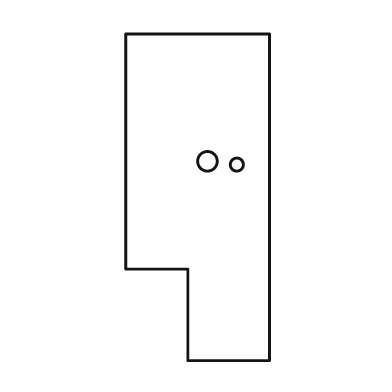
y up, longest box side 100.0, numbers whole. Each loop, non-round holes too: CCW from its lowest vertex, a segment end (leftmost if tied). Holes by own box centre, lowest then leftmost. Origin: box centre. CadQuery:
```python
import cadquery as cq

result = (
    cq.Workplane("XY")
    .moveTo(-3.0, -50.0)
    .lineTo(22.0, -50.0)
    .lineTo(22.0, 50.0)
    .lineTo(-22.0, 50.0)
    .lineTo(-22.0, -22.0)
    .lineTo(-3.0, -22.0)
    .close()
    .moveTo(12.0, 10.0)
    .circle(2.0)
    .moveTo(3.0, 11.0)
    .circle(3.0)
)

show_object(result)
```